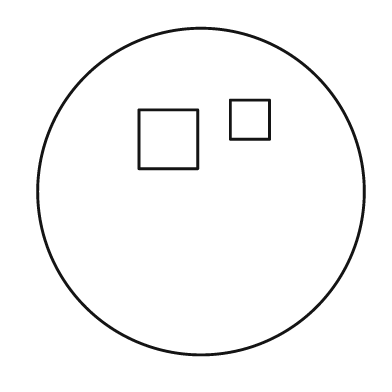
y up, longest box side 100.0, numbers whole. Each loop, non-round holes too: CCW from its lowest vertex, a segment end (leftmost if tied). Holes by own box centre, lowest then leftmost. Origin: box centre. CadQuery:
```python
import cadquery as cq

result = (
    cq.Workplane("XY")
    .moveTo(0.0, 0.0)
    .circle(50.0)
    .moveTo(-19.0, 7.0)
    .lineTo(-1.0, 7.0)
    .lineTo(-1.0, 25.0)
    .lineTo(-19.0, 25.0)
    .close()
    .moveTo(9.0, 16.0)
    .lineTo(21.0, 16.0)
    .lineTo(21.0, 28.0)
    .lineTo(9.0, 28.0)
    .close()
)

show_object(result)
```